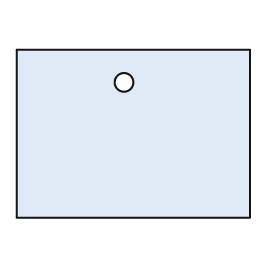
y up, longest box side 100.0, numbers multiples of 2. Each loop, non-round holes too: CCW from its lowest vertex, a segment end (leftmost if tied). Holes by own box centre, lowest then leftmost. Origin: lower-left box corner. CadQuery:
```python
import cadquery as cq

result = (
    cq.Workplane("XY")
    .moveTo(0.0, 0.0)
    .lineTo(100.0, 0.0)
    .lineTo(100.0, 72.0)
    .lineTo(0.0, 72.0)
    .close()
    .moveTo(46.0, 58.0)
    .circle(4.0)
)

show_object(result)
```